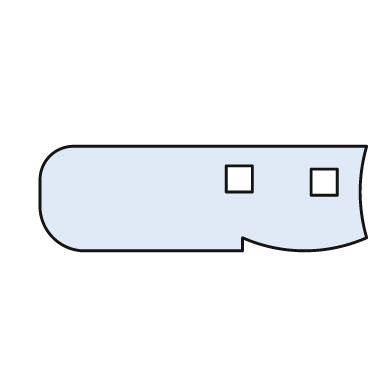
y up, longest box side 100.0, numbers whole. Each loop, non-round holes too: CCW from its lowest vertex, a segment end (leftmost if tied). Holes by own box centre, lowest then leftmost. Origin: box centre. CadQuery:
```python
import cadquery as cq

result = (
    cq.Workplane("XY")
    .moveTo(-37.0, -16.0)
    .lineTo(12.0, -16.0)
    .lineTo(12.0, -12.0)
    .threePointArc((31.0, -16.0), (50.0, -12.0))
    .threePointArc((48.0, 2.0), (50.0, 16.0))
    .lineTo(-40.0, 16.0)
    .threePointArc((-47.0, 13.0), (-50.0, 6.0))
    .lineTo(-50.0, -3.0)
    .threePointArc((-46.0, -12.0), (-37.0, -16.0))
    .close()
    .moveTo(33.0, 1.0)
    .lineTo(41.0, 1.0)
    .lineTo(41.0, 9.0)
    .lineTo(33.0, 9.0)
    .close()
    .moveTo(7.0, 2.0)
    .lineTo(15.0, 2.0)
    .lineTo(15.0, 10.0)
    .lineTo(7.0, 10.0)
    .close()
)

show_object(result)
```